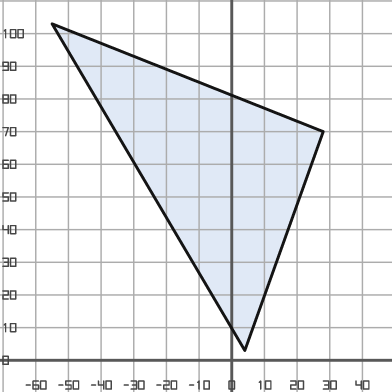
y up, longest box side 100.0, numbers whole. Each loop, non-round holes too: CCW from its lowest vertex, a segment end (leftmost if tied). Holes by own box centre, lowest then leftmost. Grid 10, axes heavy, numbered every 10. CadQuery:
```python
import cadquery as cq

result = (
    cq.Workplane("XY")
    .moveTo(4.0, 3.0)
    .lineTo(28.0, 70.0)
    .lineTo(-55.0, 103.0)
    .close()
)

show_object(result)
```